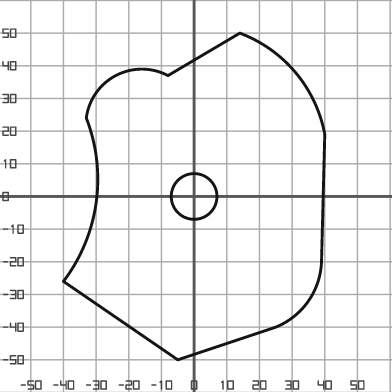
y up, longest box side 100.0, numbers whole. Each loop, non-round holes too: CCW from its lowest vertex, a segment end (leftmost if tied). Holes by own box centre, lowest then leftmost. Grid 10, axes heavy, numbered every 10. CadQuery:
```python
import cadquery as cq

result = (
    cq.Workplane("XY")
    .moveTo(-5.0, -50.0)
    .lineTo(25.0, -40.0)
    .threePointArc((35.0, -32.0), (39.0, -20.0))
    .lineTo(40.0, 19.0)
    .threePointArc((31.0, 38.0), (14.0, 50.0))
    .lineTo(-8.0, 37.0)
    .threePointArc((-24.0, 37.0), (-33.0, 24.0))
    .threePointArc((-30.0, -2.0), (-40.0, -26.0))
    .close()
    .moveTo(0.0, 0.0)
    .circle(7.0)
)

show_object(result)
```